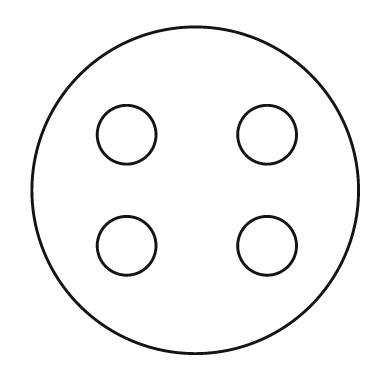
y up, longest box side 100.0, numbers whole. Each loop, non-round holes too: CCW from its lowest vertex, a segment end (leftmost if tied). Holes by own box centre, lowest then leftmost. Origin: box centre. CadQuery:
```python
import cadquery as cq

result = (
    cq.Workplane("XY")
    .moveTo(0.0, 0.0)
    .circle(50.0)
    .moveTo(-21.0, -17.0)
    .circle(9.0)
    .moveTo(22.0, -17.0)
    .circle(9.0)
    .moveTo(-21.0, 17.0)
    .circle(9.0)
    .moveTo(22.0, 17.0)
    .circle(9.0)
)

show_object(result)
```